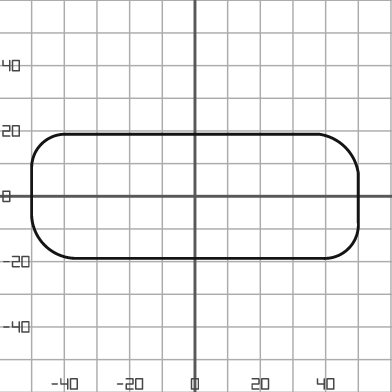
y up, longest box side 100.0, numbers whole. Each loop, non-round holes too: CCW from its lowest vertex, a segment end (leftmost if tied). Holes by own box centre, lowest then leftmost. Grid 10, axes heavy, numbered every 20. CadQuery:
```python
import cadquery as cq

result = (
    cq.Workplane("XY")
    .moveTo(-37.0, -19.0)
    .lineTo(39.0, -19.0)
    .threePointArc((47.0, -16.0), (50.0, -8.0))
    .lineTo(50.0, 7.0)
    .threePointArc((46.0, 15.0), (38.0, 19.0))
    .lineTo(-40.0, 19.0)
    .threePointArc((-47.0, 16.0), (-50.0, 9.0))
    .lineTo(-50.0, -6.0)
    .threePointArc((-46.0, -15.0), (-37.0, -19.0))
    .close()
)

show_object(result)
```